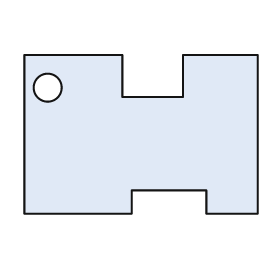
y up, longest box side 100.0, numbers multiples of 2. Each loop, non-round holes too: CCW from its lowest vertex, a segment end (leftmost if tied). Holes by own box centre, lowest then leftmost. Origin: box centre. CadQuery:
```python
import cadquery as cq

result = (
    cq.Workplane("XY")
    .moveTo(-50.0, -34.0)
    .lineTo(-4.0, -34.0)
    .lineTo(-4.0, -24.0)
    .lineTo(28.0, -24.0)
    .lineTo(28.0, -34.0)
    .lineTo(50.0, -34.0)
    .lineTo(50.0, 34.0)
    .lineTo(18.0, 34.0)
    .lineTo(18.0, 16.0)
    .lineTo(-8.0, 16.0)
    .lineTo(-8.0, 34.0)
    .lineTo(-50.0, 34.0)
    .close()
    .moveTo(-40.0, 20.0)
    .circle(6.0)
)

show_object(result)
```